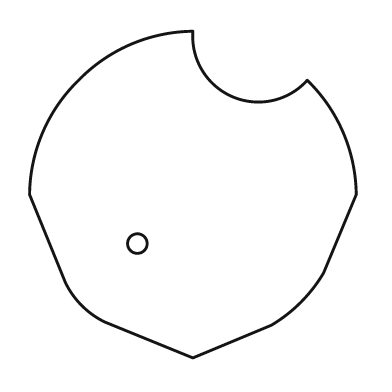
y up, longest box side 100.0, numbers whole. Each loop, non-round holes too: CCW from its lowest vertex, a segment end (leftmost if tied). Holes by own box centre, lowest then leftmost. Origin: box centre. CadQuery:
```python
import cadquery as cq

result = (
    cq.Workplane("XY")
    .moveTo(0.0, -50.0)
    .lineTo(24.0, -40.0)
    .threePointArc((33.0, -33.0), (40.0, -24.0))
    .lineTo(50.0, 0.0)
    .threePointArc((46.0, 19.0), (35.0, 35.0))
    .threePointArc((12.0, 30.0), (0.0, 50.0))
    .threePointArc((-19.0, 46.0), (-35.0, 35.0))
    .threePointArc((-46.0, 19.0), (-50.0, 0.0))
    .lineTo(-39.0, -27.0)
    .threePointArc((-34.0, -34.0), (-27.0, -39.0))
    .close()
    .moveTo(-17.0, -15.0)
    .circle(3.0)
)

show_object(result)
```